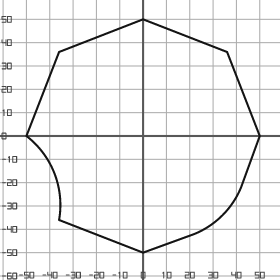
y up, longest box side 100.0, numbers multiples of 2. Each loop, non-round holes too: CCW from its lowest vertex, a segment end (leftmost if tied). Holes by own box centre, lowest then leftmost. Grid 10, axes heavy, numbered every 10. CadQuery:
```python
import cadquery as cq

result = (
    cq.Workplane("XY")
    .moveTo(0.0, -50.0)
    .lineTo(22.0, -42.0)
    .threePointArc((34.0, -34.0), (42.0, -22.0))
    .lineTo(50.0, 0.0)
    .lineTo(36.0, 36.0)
    .lineTo(0.0, 50.0)
    .lineTo(-36.0, 36.0)
    .lineTo(-50.0, 0.0)
    .threePointArc((-38.0, -16.0), (-36.0, -36.0))
    .close()
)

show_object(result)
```